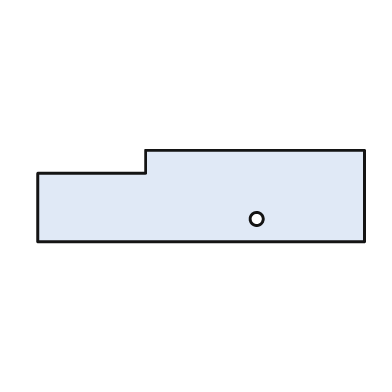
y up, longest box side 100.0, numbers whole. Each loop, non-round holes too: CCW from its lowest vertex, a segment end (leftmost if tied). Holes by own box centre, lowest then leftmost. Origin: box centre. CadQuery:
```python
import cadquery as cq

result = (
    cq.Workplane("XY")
    .moveTo(-50.0, -14.0)
    .lineTo(50.0, -14.0)
    .lineTo(50.0, 14.0)
    .lineTo(-17.0, 14.0)
    .lineTo(-17.0, 7.0)
    .lineTo(-50.0, 7.0)
    .close()
    .moveTo(17.0, -7.0)
    .circle(2.0)
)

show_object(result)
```